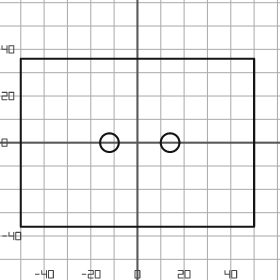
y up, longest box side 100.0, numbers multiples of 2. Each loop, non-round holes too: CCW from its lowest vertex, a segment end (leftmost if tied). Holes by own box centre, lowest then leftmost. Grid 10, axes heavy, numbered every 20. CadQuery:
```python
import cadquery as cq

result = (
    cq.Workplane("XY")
    .moveTo(-50.0, -36.0)
    .lineTo(50.0, -36.0)
    .lineTo(50.0, 36.0)
    .lineTo(-50.0, 36.0)
    .close()
    .moveTo(-12.0, 0.0)
    .circle(4.0)
    .moveTo(14.0, 0.0)
    .circle(4.0)
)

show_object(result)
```